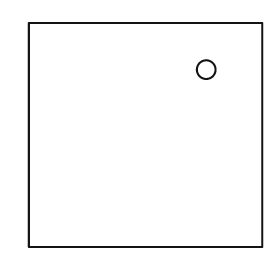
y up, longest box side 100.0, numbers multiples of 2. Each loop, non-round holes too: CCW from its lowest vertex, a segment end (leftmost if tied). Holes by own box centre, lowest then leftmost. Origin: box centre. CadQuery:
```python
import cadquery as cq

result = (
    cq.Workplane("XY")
    .moveTo(-50.0, -48.0)
    .lineTo(50.0, -48.0)
    .lineTo(50.0, 48.0)
    .lineTo(-50.0, 48.0)
    .close()
    .moveTo(26.0, 28.0)
    .circle(4.0)
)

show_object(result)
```